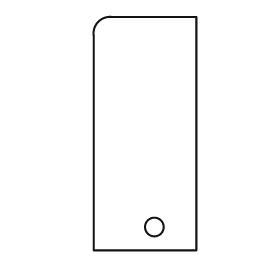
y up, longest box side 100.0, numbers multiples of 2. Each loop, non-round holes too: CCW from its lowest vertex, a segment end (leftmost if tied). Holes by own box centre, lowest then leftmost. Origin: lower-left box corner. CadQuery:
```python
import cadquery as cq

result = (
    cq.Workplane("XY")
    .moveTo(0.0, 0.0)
    .lineTo(44.0, 0.0)
    .lineTo(44.0, 100.0)
    .lineTo(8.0, 100.0)
    .threePointArc((2.0, 98.0), (0.0, 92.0))
    .close()
    .moveTo(26.0, 10.0)
    .circle(4.0)
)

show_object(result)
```